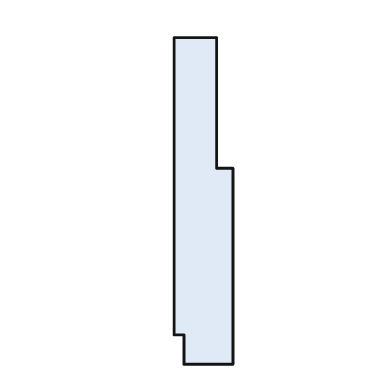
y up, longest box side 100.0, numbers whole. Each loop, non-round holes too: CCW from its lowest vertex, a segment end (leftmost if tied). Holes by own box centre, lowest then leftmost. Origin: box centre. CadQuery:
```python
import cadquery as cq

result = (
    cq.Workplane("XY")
    .moveTo(-6.0, -50.0)
    .lineTo(9.0, -50.0)
    .lineTo(9.0, 10.0)
    .lineTo(4.0, 10.0)
    .lineTo(4.0, 50.0)
    .lineTo(-9.0, 50.0)
    .lineTo(-9.0, -41.0)
    .lineTo(-6.0, -41.0)
    .close()
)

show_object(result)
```